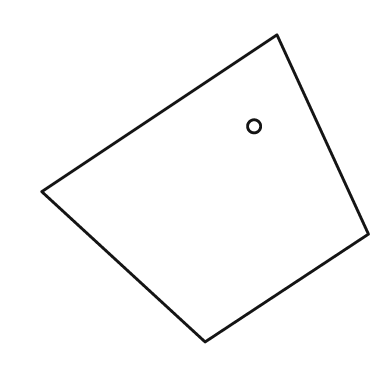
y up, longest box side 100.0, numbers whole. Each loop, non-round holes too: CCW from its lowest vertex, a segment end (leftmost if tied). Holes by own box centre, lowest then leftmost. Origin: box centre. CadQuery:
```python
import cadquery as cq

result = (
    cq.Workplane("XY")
    .moveTo(0.0, -47.0)
    .lineTo(50.0, -14.0)
    .lineTo(22.0, 47.0)
    .lineTo(-50.0, -1.0)
    .close()
    .moveTo(15.0, 19.0)
    .circle(2.0)
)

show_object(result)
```